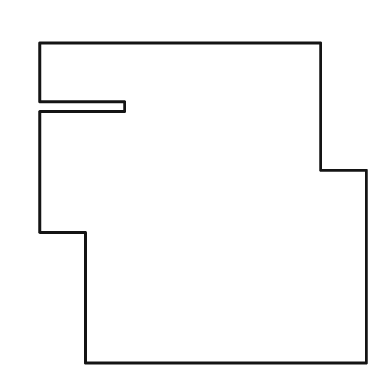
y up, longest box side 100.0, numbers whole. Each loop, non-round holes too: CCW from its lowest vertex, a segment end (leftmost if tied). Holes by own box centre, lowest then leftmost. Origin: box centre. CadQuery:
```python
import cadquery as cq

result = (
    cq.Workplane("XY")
    .moveTo(-36.0, -49.0)
    .lineTo(50.0, -49.0)
    .lineTo(50.0, 10.0)
    .lineTo(36.0, 10.0)
    .lineTo(36.0, 49.0)
    .lineTo(-50.0, 49.0)
    .lineTo(-50.0, 31.0)
    .lineTo(-24.0, 31.0)
    .lineTo(-24.0, 28.0)
    .lineTo(-50.0, 28.0)
    .lineTo(-50.0, -9.0)
    .lineTo(-36.0, -9.0)
    .close()
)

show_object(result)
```